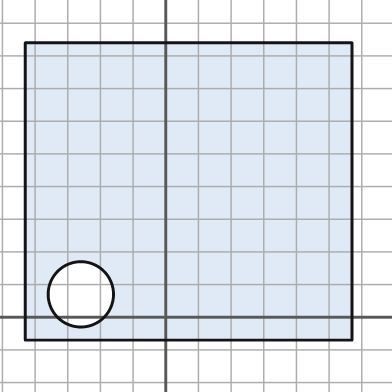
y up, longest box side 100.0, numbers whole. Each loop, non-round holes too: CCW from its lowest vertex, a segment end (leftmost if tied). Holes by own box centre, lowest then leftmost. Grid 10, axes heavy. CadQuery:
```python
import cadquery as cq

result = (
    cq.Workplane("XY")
    .moveTo(-43.0, -7.0)
    .lineTo(57.0, -7.0)
    .lineTo(57.0, 84.0)
    .lineTo(-43.0, 84.0)
    .close()
    .moveTo(-26.0, 7.0)
    .circle(10.0)
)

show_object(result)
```